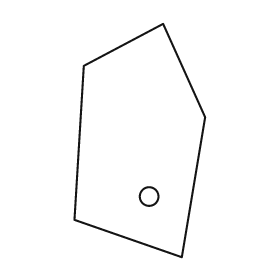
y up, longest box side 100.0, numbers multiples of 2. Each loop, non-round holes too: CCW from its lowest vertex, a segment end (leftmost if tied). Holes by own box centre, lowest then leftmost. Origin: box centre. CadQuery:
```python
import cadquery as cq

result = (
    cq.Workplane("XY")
    .moveTo(18.0, -50.0)
    .lineTo(28.0, 10.0)
    .lineTo(10.0, 50.0)
    .lineTo(-24.0, 32.0)
    .lineTo(-28.0, -34.0)
    .close()
    .moveTo(4.0, -24.0)
    .circle(4.0)
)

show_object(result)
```